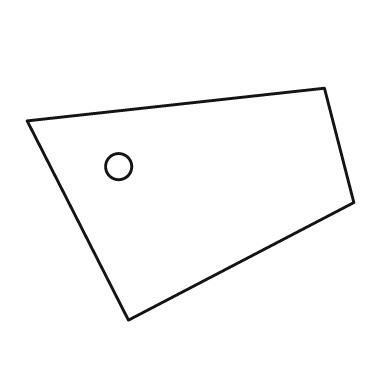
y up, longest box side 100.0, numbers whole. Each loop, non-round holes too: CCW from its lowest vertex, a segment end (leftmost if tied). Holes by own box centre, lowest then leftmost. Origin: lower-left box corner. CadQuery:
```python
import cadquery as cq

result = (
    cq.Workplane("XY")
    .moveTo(31.0, 0.0)
    .lineTo(100.0, 36.0)
    .lineTo(91.0, 71.0)
    .lineTo(0.0, 61.0)
    .close()
    .moveTo(28.0, 47.0)
    .circle(4.0)
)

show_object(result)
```